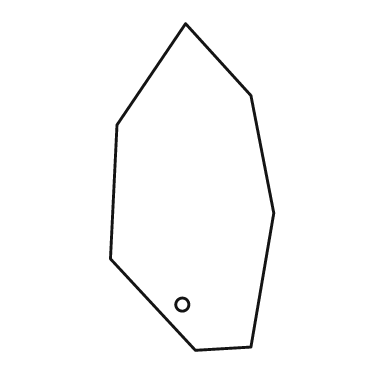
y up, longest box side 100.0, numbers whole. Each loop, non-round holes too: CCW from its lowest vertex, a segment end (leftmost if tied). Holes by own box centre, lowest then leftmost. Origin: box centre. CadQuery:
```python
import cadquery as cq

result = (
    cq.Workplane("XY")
    .moveTo(1.0, -50.0)
    .lineTo(18.0, -49.0)
    .lineTo(25.0, -8.0)
    .lineTo(18.0, 28.0)
    .lineTo(-2.0, 50.0)
    .lineTo(-23.0, 19.0)
    .lineTo(-25.0, -22.0)
    .close()
    .moveTo(-3.0, -36.0)
    .circle(2.0)
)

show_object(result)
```